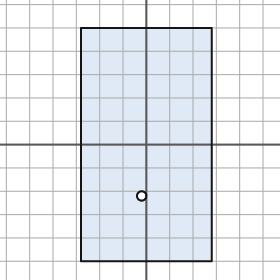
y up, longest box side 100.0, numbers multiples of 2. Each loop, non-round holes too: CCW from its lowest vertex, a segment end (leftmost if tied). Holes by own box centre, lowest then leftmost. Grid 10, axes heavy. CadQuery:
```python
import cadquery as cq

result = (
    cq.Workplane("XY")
    .moveTo(-28.0, -50.0)
    .lineTo(28.0, -50.0)
    .lineTo(28.0, 50.0)
    .lineTo(-28.0, 50.0)
    .close()
    .moveTo(-2.0, -22.0)
    .circle(2.0)
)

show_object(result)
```